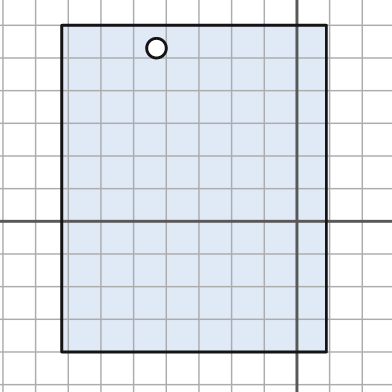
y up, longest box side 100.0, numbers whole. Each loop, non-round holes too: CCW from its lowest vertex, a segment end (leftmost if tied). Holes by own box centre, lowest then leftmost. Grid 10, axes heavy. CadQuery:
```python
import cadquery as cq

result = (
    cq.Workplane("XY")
    .moveTo(-72.0, -40.0)
    .lineTo(9.0, -40.0)
    .lineTo(9.0, 60.0)
    .lineTo(-72.0, 60.0)
    .close()
    .moveTo(-43.0, 53.0)
    .circle(3.0)
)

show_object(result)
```